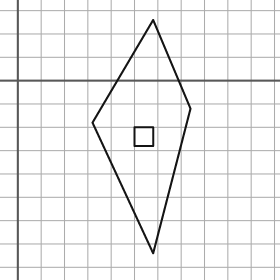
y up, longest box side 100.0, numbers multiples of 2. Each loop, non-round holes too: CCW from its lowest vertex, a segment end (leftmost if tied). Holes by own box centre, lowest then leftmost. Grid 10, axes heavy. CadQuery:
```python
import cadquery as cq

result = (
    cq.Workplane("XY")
    .moveTo(58.0, -74.0)
    .lineTo(74.0, -12.0)
    .lineTo(58.0, 26.0)
    .lineTo(32.0, -18.0)
    .close()
    .moveTo(50.0, -28.0)
    .lineTo(58.0, -28.0)
    .lineTo(58.0, -20.0)
    .lineTo(50.0, -20.0)
    .close()
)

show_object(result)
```